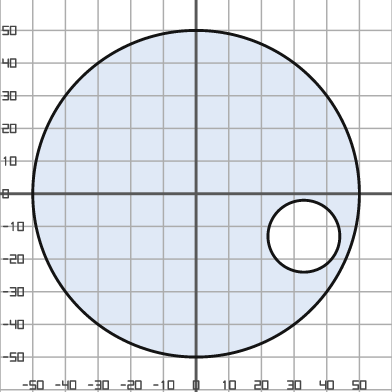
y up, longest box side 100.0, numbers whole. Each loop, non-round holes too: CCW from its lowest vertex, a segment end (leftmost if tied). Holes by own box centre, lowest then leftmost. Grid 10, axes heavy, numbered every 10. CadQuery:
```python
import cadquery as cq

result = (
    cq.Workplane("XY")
    .moveTo(0.0, 0.0)
    .circle(50.0)
    .moveTo(33.0, -13.0)
    .circle(11.0)
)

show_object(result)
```